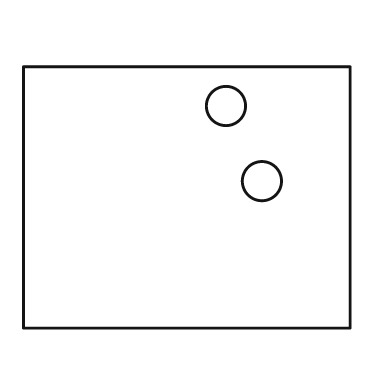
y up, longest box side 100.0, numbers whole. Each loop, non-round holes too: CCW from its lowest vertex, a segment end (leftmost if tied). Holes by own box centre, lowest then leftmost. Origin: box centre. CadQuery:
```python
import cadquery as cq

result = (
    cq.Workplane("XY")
    .moveTo(-50.0, -40.0)
    .lineTo(50.0, -40.0)
    .lineTo(50.0, 40.0)
    .lineTo(-50.0, 40.0)
    .close()
    .moveTo(23.0, 5.0)
    .circle(6.0)
    .moveTo(12.0, 28.0)
    .circle(6.0)
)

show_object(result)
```